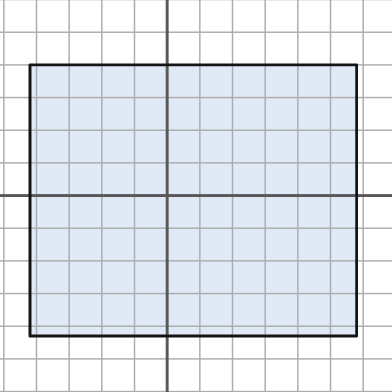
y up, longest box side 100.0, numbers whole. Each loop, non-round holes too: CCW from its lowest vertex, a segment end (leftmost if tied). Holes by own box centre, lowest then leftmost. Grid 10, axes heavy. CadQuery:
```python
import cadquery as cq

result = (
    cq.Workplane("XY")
    .moveTo(-42.0, -43.0)
    .lineTo(58.0, -43.0)
    .lineTo(58.0, 40.0)
    .lineTo(-42.0, 40.0)
    .close()
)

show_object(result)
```